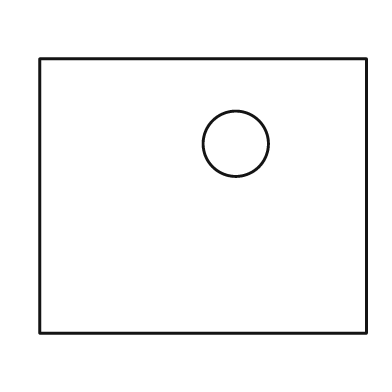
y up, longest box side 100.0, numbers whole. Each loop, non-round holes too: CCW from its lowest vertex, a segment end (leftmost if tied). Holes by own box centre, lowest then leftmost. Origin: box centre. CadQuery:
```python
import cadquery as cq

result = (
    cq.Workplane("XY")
    .moveTo(-50.0, -42.0)
    .lineTo(50.0, -42.0)
    .lineTo(50.0, 42.0)
    .lineTo(-50.0, 42.0)
    .close()
    .moveTo(10.0, 16.0)
    .circle(10.0)
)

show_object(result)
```